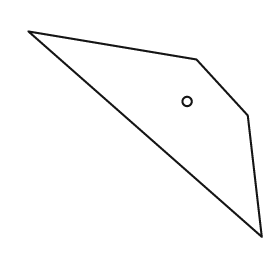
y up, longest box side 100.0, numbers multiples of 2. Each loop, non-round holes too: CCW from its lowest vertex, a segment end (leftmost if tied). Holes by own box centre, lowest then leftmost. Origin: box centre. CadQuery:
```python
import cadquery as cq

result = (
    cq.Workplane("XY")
    .moveTo(50.0, -44.0)
    .lineTo(44.0, 8.0)
    .lineTo(22.0, 32.0)
    .lineTo(-50.0, 44.0)
    .close()
    .moveTo(18.0, 14.0)
    .circle(2.0)
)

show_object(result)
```